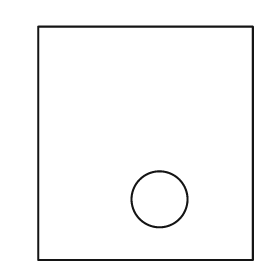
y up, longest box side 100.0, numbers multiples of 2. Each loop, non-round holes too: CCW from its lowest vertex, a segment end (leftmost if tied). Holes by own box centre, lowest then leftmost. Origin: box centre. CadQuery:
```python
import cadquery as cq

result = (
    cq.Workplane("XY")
    .moveTo(-46.0, -50.0)
    .lineTo(46.0, -50.0)
    .lineTo(46.0, 50.0)
    .lineTo(-46.0, 50.0)
    .close()
    .moveTo(6.0, -24.0)
    .circle(12.0)
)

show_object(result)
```